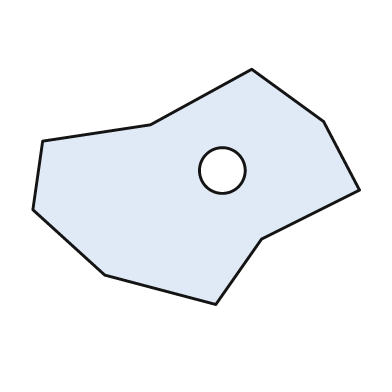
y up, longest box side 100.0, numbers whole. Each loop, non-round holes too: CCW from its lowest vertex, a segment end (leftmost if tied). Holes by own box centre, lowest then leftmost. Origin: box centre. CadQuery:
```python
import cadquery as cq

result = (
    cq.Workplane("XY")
    .moveTo(6.0, -36.0)
    .lineTo(20.0, -16.0)
    .lineTo(50.0, -1.0)
    .lineTo(39.0, 20.0)
    .lineTo(17.0, 36.0)
    .lineTo(-14.0, 19.0)
    .lineTo(-47.0, 14.0)
    .lineTo(-50.0, -7.0)
    .lineTo(-28.0, -27.0)
    .close()
    .moveTo(8.0, 5.0)
    .circle(7.0)
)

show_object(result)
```